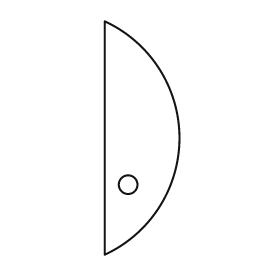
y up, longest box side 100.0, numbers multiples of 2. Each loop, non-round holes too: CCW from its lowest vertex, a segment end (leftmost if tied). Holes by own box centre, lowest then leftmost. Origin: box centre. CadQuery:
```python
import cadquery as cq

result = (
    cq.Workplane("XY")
    .moveTo(-16.0, -50.0)
    .threePointArc((16.0, 0.0), (-16.0, 50.0))
    .close()
    .moveTo(-6.0, -20.0)
    .circle(4.0)
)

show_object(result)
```